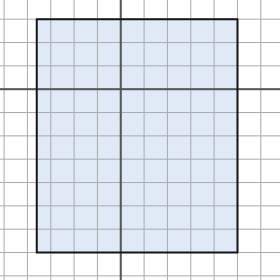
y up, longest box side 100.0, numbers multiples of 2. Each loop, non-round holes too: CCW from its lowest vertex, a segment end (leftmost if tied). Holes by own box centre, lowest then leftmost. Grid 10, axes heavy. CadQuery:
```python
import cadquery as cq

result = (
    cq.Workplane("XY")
    .moveTo(-36.0, -70.0)
    .lineTo(50.0, -70.0)
    .lineTo(50.0, 30.0)
    .lineTo(-36.0, 30.0)
    .close()
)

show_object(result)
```